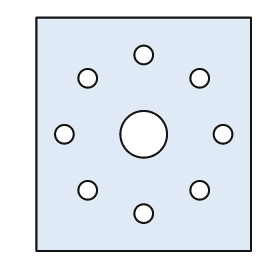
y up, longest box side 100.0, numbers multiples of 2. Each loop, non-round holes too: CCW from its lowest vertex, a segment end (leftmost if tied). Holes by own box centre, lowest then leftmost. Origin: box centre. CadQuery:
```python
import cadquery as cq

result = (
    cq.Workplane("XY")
    .moveTo(-46.0, -50.0)
    .lineTo(46.0, -50.0)
    .lineTo(46.0, 50.0)
    .lineTo(-46.0, 50.0)
    .close()
    .moveTo(0.0, -34.0)
    .circle(4.0)
    .moveTo(-24.0, -24.0)
    .circle(4.0)
    .moveTo(24.0, -24.0)
    .circle(4.0)
    .moveTo(-34.0, 0.0)
    .circle(4.0)
    .moveTo(0.0, 0.0)
    .circle(10.0)
    .moveTo(34.0, 0.0)
    .circle(4.0)
    .moveTo(-24.0, 24.0)
    .circle(4.0)
    .moveTo(24.0, 24.0)
    .circle(4.0)
    .moveTo(0.0, 34.0)
    .circle(4.0)
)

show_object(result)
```